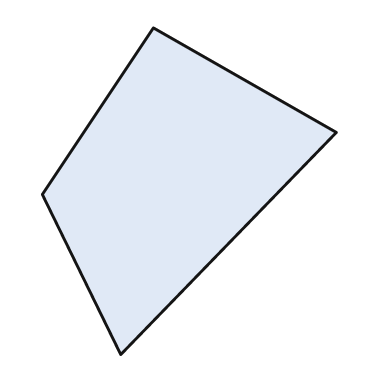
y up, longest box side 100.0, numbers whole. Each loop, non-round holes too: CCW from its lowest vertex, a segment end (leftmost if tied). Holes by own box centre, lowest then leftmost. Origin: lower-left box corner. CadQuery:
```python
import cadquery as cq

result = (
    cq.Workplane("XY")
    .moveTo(24.0, 0.0)
    .lineTo(90.0, 68.0)
    .lineTo(34.0, 100.0)
    .lineTo(0.0, 49.0)
    .close()
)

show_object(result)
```